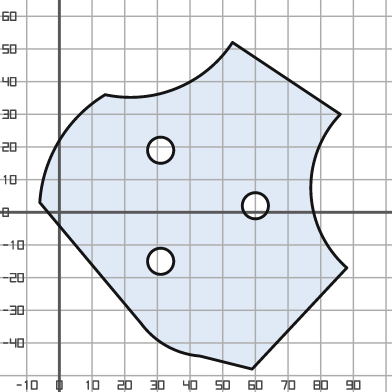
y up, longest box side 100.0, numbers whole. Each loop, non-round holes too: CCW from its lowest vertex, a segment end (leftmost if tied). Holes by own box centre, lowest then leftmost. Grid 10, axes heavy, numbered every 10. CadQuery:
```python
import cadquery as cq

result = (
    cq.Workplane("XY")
    .moveTo(59.0, -48.0)
    .lineTo(88.0, -17.0)
    .threePointArc((77.0, 6.0), (86.0, 30.0))
    .lineTo(53.0, 52.0)
    .threePointArc((36.0, 38.0), (14.0, 36.0))
    .threePointArc((0.0, 22.0), (-6.0, 3.0))
    .lineTo(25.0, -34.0)
    .threePointArc((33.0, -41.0), (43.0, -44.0))
    .close()
    .moveTo(31.0, -15.0)
    .circle(4.0)
    .moveTo(60.0, 2.0)
    .circle(4.0)
    .moveTo(31.0, 19.0)
    .circle(4.0)
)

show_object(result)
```